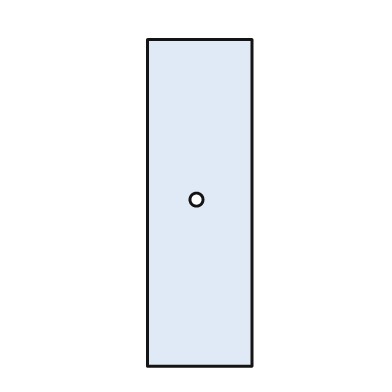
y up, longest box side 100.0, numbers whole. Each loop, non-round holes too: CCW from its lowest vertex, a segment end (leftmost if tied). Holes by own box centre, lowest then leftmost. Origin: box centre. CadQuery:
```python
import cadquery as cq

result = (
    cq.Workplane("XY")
    .moveTo(-16.0, -50.0)
    .lineTo(16.0, -50.0)
    .lineTo(16.0, 50.0)
    .lineTo(-16.0, 50.0)
    .close()
    .moveTo(-1.0, 1.0)
    .circle(2.0)
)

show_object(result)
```